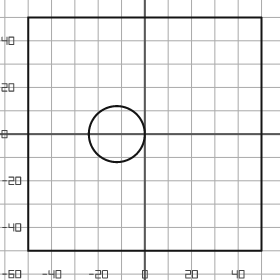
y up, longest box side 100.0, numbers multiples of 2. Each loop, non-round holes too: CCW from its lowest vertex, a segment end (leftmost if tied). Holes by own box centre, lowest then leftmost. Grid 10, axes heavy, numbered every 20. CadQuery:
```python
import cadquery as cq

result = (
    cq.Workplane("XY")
    .moveTo(-50.0, -50.0)
    .lineTo(50.0, -50.0)
    .lineTo(50.0, 50.0)
    .lineTo(-50.0, 50.0)
    .close()
    .moveTo(-12.0, 0.0)
    .circle(12.0)
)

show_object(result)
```